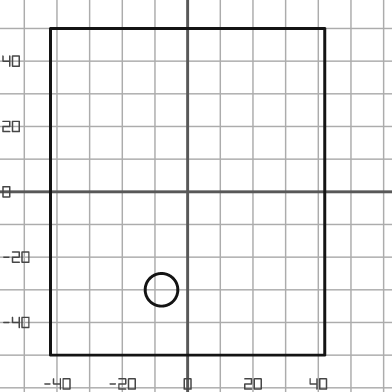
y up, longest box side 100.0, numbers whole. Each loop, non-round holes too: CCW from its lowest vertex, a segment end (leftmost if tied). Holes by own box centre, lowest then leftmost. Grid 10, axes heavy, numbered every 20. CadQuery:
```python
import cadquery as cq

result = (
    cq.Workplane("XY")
    .moveTo(-42.0, -50.0)
    .lineTo(42.0, -50.0)
    .lineTo(42.0, 50.0)
    .lineTo(-42.0, 50.0)
    .close()
    .moveTo(-8.0, -30.0)
    .circle(5.0)
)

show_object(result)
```